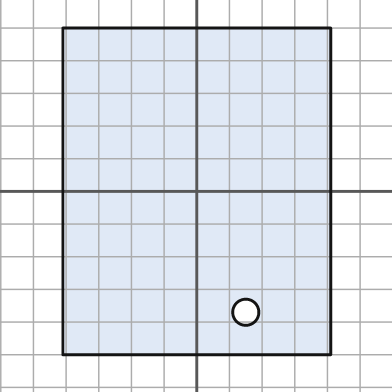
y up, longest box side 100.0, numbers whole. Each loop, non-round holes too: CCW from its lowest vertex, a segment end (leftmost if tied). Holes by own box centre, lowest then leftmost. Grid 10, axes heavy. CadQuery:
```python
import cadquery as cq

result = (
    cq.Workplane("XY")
    .moveTo(-41.0, -50.0)
    .lineTo(41.0, -50.0)
    .lineTo(41.0, 50.0)
    .lineTo(-41.0, 50.0)
    .close()
    .moveTo(15.0, -37.0)
    .circle(4.0)
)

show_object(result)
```